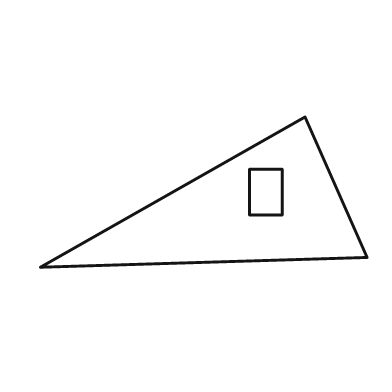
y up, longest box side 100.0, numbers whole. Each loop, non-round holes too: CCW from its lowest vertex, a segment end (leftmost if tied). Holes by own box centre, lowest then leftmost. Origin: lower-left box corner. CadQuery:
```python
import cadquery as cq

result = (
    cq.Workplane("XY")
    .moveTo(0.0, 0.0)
    .lineTo(100.0, 3.0)
    .lineTo(81.0, 46.0)
    .close()
    .moveTo(64.0, 16.0)
    .lineTo(74.0, 16.0)
    .lineTo(74.0, 30.0)
    .lineTo(64.0, 30.0)
    .close()
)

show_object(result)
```